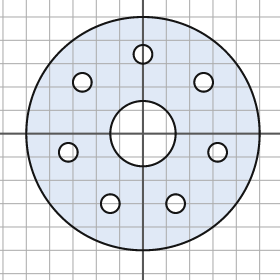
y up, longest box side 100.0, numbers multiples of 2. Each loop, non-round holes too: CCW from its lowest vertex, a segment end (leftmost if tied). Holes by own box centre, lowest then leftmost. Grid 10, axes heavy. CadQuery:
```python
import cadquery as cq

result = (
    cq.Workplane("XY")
    .moveTo(0.0, 0.0)
    .circle(50.0)
    .moveTo(-14.0, -30.0)
    .circle(4.0)
    .moveTo(14.0, -30.0)
    .circle(4.0)
    .moveTo(-32.0, -8.0)
    .circle(4.0)
    .moveTo(32.0, -8.0)
    .circle(4.0)
    .moveTo(0.0, 0.0)
    .circle(14.0)
    .moveTo(-26.0, 22.0)
    .circle(4.0)
    .moveTo(26.0, 22.0)
    .circle(4.0)
    .moveTo(0.0, 34.0)
    .circle(4.0)
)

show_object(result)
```